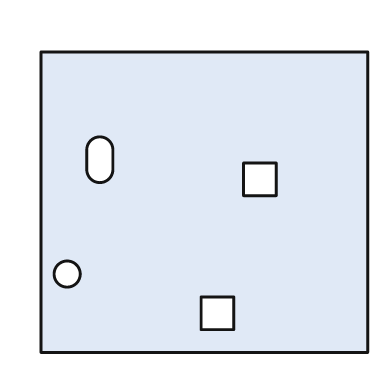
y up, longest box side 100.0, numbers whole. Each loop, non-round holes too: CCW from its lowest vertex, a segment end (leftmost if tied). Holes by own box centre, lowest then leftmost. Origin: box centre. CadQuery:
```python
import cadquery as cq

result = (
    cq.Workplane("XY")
    .moveTo(-50.0, -46.0)
    .lineTo(50.0, -46.0)
    .lineTo(50.0, 46.0)
    .lineTo(-50.0, 46.0)
    .close()
    .moveTo(-1.0, -39.0)
    .lineTo(9.0, -39.0)
    .lineTo(9.0, -29.0)
    .lineTo(-1.0, -29.0)
    .close()
    .moveTo(-42.0, -22.0)
    .circle(4.0)
    .moveTo(12.0, 2.0)
    .lineTo(22.0, 2.0)
    .lineTo(22.0, 12.0)
    .lineTo(12.0, 12.0)
    .close()
    .moveTo(-36.0, 10.0)
    .threePointArc((-32.0, 6.0), (-28.0, 10.0))
    .lineTo(-28.0, 16.0)
    .threePointArc((-32.0, 20.0), (-36.0, 16.0))
    .close()
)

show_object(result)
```